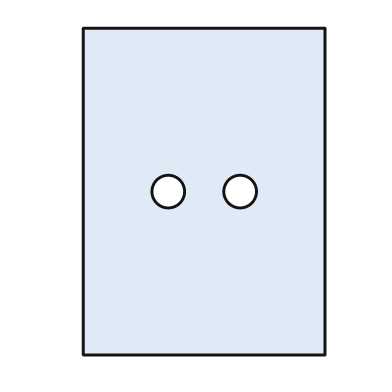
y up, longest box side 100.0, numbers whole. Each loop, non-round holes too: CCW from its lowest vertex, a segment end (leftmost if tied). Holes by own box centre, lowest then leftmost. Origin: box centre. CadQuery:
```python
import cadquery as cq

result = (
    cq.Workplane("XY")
    .moveTo(-37.0, -50.0)
    .lineTo(37.0, -50.0)
    .lineTo(37.0, 50.0)
    .lineTo(-37.0, 50.0)
    .close()
    .moveTo(-11.0, 0.0)
    .circle(5.0)
    .moveTo(11.0, 0.0)
    .circle(5.0)
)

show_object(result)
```